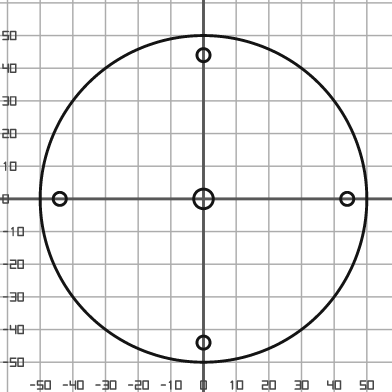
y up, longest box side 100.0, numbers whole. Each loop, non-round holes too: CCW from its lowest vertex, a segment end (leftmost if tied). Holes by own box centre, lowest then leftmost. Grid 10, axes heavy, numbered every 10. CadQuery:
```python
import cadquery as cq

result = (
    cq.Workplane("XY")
    .moveTo(0.0, 0.0)
    .circle(50.0)
    .moveTo(0.0, -44.0)
    .circle(2.0)
    .moveTo(-44.0, 0.0)
    .circle(2.0)
    .moveTo(0.0, 0.0)
    .circle(3.0)
    .moveTo(44.0, 0.0)
    .circle(2.0)
    .moveTo(0.0, 44.0)
    .circle(2.0)
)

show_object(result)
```